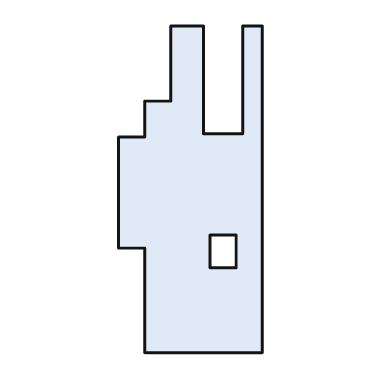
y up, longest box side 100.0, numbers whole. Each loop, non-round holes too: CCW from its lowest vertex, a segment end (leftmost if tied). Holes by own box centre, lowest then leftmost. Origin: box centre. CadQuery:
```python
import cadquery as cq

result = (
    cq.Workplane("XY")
    .moveTo(-14.0, -50.0)
    .lineTo(22.0, -50.0)
    .lineTo(22.0, 50.0)
    .lineTo(16.0, 50.0)
    .lineTo(16.0, 17.0)
    .lineTo(4.0, 17.0)
    .lineTo(4.0, 50.0)
    .lineTo(-6.0, 50.0)
    .lineTo(-6.0, 27.0)
    .lineTo(-14.0, 27.0)
    .lineTo(-14.0, 16.0)
    .lineTo(-22.0, 16.0)
    .lineTo(-22.0, -18.0)
    .lineTo(-14.0, -18.0)
    .close()
    .moveTo(6.0, -24.0)
    .lineTo(14.0, -24.0)
    .lineTo(14.0, -14.0)
    .lineTo(6.0, -14.0)
    .close()
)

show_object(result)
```